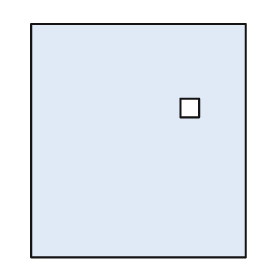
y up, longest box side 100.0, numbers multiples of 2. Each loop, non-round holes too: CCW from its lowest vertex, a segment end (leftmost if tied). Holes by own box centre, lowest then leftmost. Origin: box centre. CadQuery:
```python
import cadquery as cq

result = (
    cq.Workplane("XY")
    .moveTo(-46.0, -50.0)
    .lineTo(46.0, -50.0)
    .lineTo(46.0, 50.0)
    .lineTo(-46.0, 50.0)
    .close()
    .moveTo(18.0, 10.0)
    .lineTo(26.0, 10.0)
    .lineTo(26.0, 18.0)
    .lineTo(18.0, 18.0)
    .close()
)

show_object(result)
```